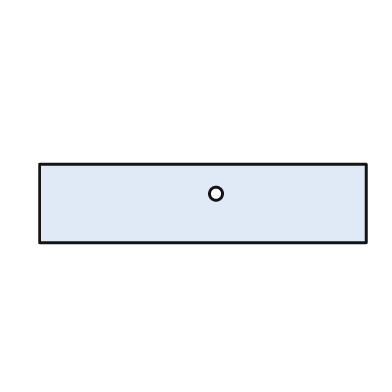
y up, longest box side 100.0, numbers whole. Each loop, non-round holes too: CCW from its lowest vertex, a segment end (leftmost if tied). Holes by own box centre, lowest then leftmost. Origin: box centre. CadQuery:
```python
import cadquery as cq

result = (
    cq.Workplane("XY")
    .moveTo(-50.0, -12.0)
    .lineTo(50.0, -12.0)
    .lineTo(50.0, 12.0)
    .lineTo(-50.0, 12.0)
    .close()
    .moveTo(4.0, 3.0)
    .circle(2.0)
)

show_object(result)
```